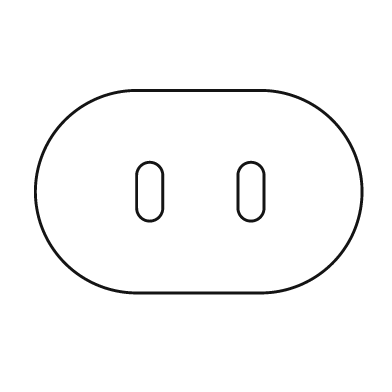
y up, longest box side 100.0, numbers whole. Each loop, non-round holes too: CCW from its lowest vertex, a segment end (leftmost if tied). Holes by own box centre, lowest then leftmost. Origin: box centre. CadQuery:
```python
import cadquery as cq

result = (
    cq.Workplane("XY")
    .moveTo(-19.0, -31.0)
    .lineTo(19.0, -31.0)
    .threePointArc((50.0, 0.0), (19.0, 31.0))
    .lineTo(-19.0, 31.0)
    .threePointArc((-50.0, 0.0), (-19.0, -31.0))
    .close()
    .moveTo(-19.0, -5.0)
    .threePointArc((-15.0, -9.0), (-11.0, -5.0))
    .lineTo(-11.0, 5.0)
    .threePointArc((-15.0, 9.0), (-19.0, 5.0))
    .close()
    .moveTo(12.0, -5.0)
    .threePointArc((16.0, -9.0), (20.0, -5.0))
    .lineTo(20.0, 5.0)
    .threePointArc((16.0, 9.0), (12.0, 5.0))
    .close()
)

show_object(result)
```